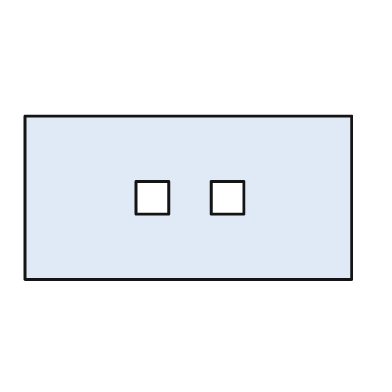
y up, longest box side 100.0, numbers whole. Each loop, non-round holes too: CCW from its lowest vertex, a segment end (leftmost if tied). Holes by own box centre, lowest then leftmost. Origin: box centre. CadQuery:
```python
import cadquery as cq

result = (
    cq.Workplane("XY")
    .moveTo(-50.0, -25.0)
    .lineTo(50.0, -25.0)
    .lineTo(50.0, 25.0)
    .lineTo(-50.0, 25.0)
    .close()
    .moveTo(-16.0, -5.0)
    .lineTo(-6.0, -5.0)
    .lineTo(-6.0, 5.0)
    .lineTo(-16.0, 5.0)
    .close()
    .moveTo(7.0, -5.0)
    .lineTo(17.0, -5.0)
    .lineTo(17.0, 5.0)
    .lineTo(7.0, 5.0)
    .close()
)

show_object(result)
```